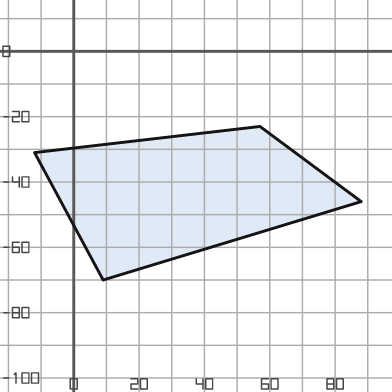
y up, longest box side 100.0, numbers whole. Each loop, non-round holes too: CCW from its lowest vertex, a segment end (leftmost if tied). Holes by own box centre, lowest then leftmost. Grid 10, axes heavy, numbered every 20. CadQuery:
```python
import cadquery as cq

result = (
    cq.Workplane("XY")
    .moveTo(9.0, -70.0)
    .lineTo(88.0, -46.0)
    .lineTo(57.0, -23.0)
    .lineTo(-12.0, -31.0)
    .close()
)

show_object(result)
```